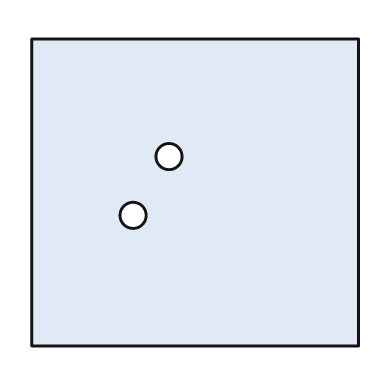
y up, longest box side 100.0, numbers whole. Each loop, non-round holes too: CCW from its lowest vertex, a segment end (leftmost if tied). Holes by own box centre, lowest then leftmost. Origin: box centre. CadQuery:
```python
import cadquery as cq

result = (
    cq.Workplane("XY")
    .moveTo(-50.0, -47.0)
    .lineTo(50.0, -47.0)
    .lineTo(50.0, 47.0)
    .lineTo(-50.0, 47.0)
    .close()
    .moveTo(-19.0, -7.0)
    .circle(4.0)
    .moveTo(-8.0, 11.0)
    .circle(4.0)
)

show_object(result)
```